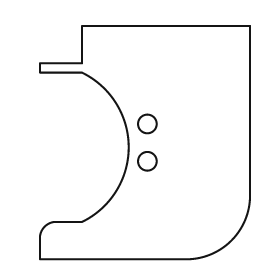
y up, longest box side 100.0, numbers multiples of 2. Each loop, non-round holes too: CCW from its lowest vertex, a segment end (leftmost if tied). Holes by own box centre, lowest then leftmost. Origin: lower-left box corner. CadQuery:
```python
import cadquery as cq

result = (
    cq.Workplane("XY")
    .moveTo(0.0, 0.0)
    .lineTo(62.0, 0.0)
    .threePointArc((82.0, 8.0), (90.0, 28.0))
    .lineTo(90.0, 100.0)
    .lineTo(18.0, 100.0)
    .lineTo(18.0, 84.0)
    .lineTo(0.0, 84.0)
    .lineTo(0.0, 80.0)
    .lineTo(18.0, 80.0)
    .threePointArc((38.0, 48.0), (18.0, 16.0))
    .lineTo(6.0, 16.0)
    .threePointArc((2.0, 14.0), (0.0, 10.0))
    .close()
    .moveTo(46.0, 42.0)
    .circle(4.0)
    .moveTo(46.0, 58.0)
    .circle(4.0)
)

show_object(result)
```